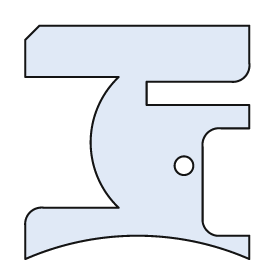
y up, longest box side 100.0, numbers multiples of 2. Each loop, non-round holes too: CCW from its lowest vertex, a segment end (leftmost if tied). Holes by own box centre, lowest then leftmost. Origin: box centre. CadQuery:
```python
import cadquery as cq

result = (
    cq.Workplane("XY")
    .moveTo(-48.0, -50.0)
    .threePointArc((0.0, -40.0), (48.0, -50.0))
    .lineTo(48.0, -40.0)
    .lineTo(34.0, -40.0)
    .threePointArc((30.0, -38.0), (28.0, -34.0))
    .lineTo(28.0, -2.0)
    .threePointArc((30.0, 4.0), (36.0, 6.0))
    .lineTo(48.0, 6.0)
    .lineTo(48.0, 16.0)
    .lineTo(4.0, 16.0)
    .lineTo(4.0, 26.0)
    .lineTo(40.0, 26.0)
    .threePointArc((46.0, 28.0), (48.0, 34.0))
    .lineTo(48.0, 50.0)
    .lineTo(-42.0, 50.0)
    .lineTo(-48.0, 44.0)
    .lineTo(-48.0, 28.0)
    .lineTo(-8.0, 28.0)
    .threePointArc((-20.0, 0.0), (-8.0, -28.0))
    .lineTo(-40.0, -28.0)
    .threePointArc((-46.0, -30.0), (-48.0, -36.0))
    .close()
    .moveTo(20.0, -10.0)
    .circle(4.0)
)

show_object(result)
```